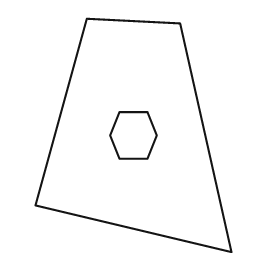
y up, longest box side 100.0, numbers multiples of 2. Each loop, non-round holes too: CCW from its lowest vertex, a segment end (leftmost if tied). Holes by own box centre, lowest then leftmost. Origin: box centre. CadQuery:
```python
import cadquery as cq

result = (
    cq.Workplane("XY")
    .moveTo(42.0, -50.0)
    .lineTo(20.0, 48.0)
    .lineTo(-20.0, 50.0)
    .lineTo(-42.0, -30.0)
    .close()
    .moveTo(-6.0, -10.0)
    .lineTo(6.0, -10.0)
    .lineTo(10.0, 0.0)
    .lineTo(6.0, 10.0)
    .lineTo(-6.0, 10.0)
    .lineTo(-10.0, 0.0)
    .close()
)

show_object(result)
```